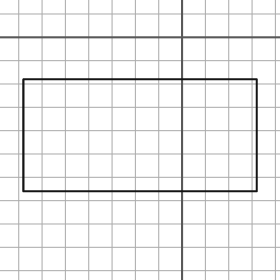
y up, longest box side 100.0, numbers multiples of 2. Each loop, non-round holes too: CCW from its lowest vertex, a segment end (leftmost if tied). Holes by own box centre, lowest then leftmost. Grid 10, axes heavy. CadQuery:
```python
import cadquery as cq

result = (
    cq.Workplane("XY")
    .moveTo(-68.0, -66.0)
    .lineTo(32.0, -66.0)
    .lineTo(32.0, -18.0)
    .lineTo(-68.0, -18.0)
    .close()
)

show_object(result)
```